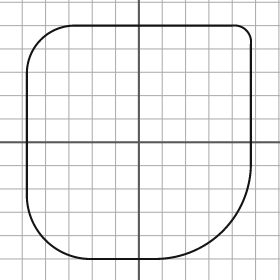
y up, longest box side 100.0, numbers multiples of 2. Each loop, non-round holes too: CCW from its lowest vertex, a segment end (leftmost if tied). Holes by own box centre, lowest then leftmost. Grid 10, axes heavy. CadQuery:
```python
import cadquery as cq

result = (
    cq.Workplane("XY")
    .moveTo(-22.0, -50.0)
    .lineTo(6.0, -50.0)
    .threePointArc((36.0, -38.0), (48.0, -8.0))
    .lineTo(48.0, 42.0)
    .threePointArc((46.0, 48.0), (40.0, 50.0))
    .lineTo(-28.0, 50.0)
    .threePointArc((-42.0, 44.0), (-48.0, 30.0))
    .lineTo(-48.0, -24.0)
    .threePointArc((-40.0, -42.0), (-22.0, -50.0))
    .close()
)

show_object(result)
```